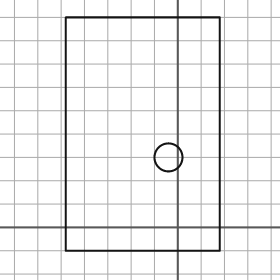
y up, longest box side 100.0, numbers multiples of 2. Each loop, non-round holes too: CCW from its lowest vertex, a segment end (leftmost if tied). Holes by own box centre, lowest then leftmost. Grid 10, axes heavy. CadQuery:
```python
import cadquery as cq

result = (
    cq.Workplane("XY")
    .moveTo(-48.0, -10.0)
    .lineTo(18.0, -10.0)
    .lineTo(18.0, 90.0)
    .lineTo(-48.0, 90.0)
    .close()
    .moveTo(-4.0, 30.0)
    .circle(6.0)
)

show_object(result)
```